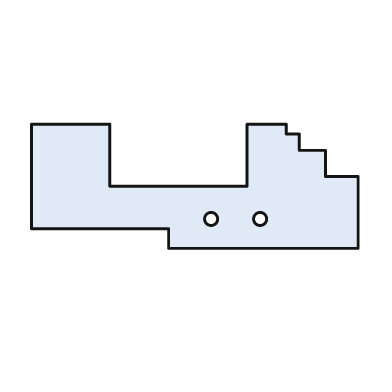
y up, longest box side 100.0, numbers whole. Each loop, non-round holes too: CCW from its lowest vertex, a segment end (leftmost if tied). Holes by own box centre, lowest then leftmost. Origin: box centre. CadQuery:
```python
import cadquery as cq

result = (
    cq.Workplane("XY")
    .moveTo(-8.0, -19.0)
    .lineTo(50.0, -19.0)
    .lineTo(50.0, 3.0)
    .lineTo(40.0, 3.0)
    .lineTo(40.0, 11.0)
    .lineTo(32.0, 11.0)
    .lineTo(32.0, 16.0)
    .lineTo(28.0, 16.0)
    .lineTo(28.0, 19.0)
    .lineTo(16.0, 19.0)
    .lineTo(16.0, 0.0)
    .lineTo(-26.0, 0.0)
    .lineTo(-26.0, 19.0)
    .lineTo(-50.0, 19.0)
    .lineTo(-50.0, -13.0)
    .lineTo(-8.0, -13.0)
    .close()
    .moveTo(5.0, -10.0)
    .circle(2.0)
    .moveTo(20.0, -10.0)
    .circle(2.0)
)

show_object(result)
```